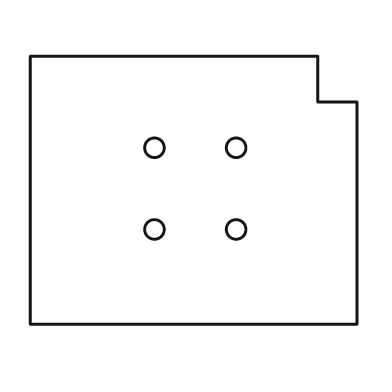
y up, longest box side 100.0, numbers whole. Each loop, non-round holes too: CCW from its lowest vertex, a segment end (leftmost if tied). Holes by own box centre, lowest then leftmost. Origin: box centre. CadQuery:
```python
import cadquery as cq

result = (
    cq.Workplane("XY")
    .moveTo(-50.0, -41.0)
    .lineTo(50.0, -41.0)
    .lineTo(50.0, 27.0)
    .lineTo(38.0, 27.0)
    .lineTo(38.0, 41.0)
    .lineTo(-50.0, 41.0)
    .close()
    .moveTo(-12.0, -12.0)
    .circle(3.0)
    .moveTo(13.0, -12.0)
    .circle(3.0)
    .moveTo(-12.0, 13.0)
    .circle(3.0)
    .moveTo(13.0, 13.0)
    .circle(3.0)
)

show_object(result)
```